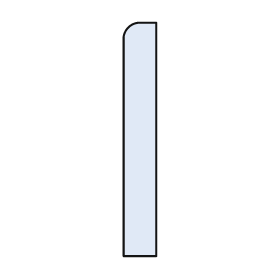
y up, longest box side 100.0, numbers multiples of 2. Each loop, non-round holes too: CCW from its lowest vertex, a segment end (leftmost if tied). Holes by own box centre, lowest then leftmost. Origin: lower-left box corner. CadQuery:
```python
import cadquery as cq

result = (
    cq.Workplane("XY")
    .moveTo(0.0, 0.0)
    .lineTo(14.0, 0.0)
    .lineTo(14.0, 100.0)
    .lineTo(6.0, 100.0)
    .threePointArc((2.0, 98.0), (0.0, 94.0))
    .close()
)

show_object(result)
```